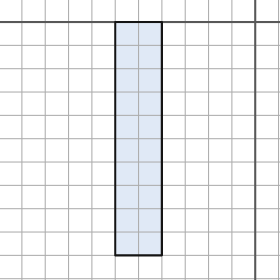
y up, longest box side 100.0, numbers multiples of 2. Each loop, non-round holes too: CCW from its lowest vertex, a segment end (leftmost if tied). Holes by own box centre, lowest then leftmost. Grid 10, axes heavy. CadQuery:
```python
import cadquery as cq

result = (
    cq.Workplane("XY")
    .moveTo(-60.0, -100.0)
    .lineTo(-40.0, -100.0)
    .lineTo(-40.0, 0.0)
    .lineTo(-60.0, 0.0)
    .close()
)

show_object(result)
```